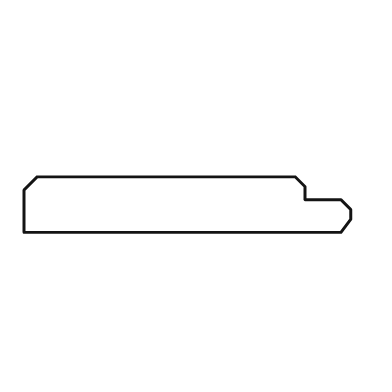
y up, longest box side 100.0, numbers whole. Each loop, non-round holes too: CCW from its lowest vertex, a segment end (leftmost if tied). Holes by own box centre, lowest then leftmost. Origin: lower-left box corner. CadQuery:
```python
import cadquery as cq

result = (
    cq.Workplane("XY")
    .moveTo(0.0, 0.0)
    .lineTo(97.0, 0.0)
    .lineTo(100.0, 4.0)
    .lineTo(100.0, 7.0)
    .lineTo(97.0, 10.0)
    .lineTo(86.0, 10.0)
    .lineTo(86.0, 14.0)
    .lineTo(83.0, 17.0)
    .lineTo(4.0, 17.0)
    .lineTo(0.0, 13.0)
    .close()
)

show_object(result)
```